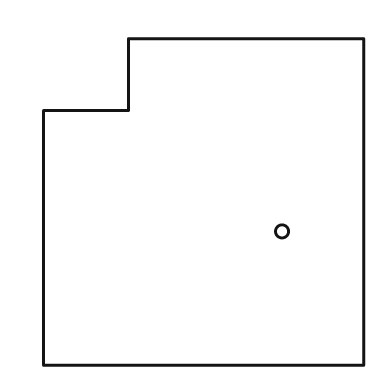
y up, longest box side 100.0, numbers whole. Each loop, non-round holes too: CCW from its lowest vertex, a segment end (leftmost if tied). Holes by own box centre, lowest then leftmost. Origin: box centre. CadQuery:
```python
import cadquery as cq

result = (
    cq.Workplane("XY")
    .moveTo(-49.0, -50.0)
    .lineTo(49.0, -50.0)
    .lineTo(49.0, 50.0)
    .lineTo(-23.0, 50.0)
    .lineTo(-23.0, 28.0)
    .lineTo(-49.0, 28.0)
    .close()
    .moveTo(24.0, -9.0)
    .circle(2.0)
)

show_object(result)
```